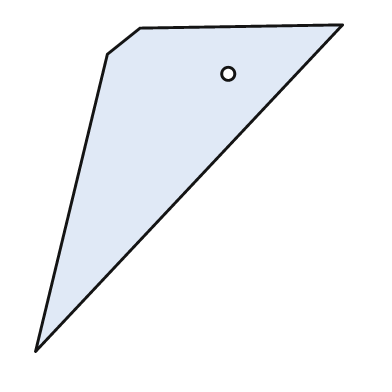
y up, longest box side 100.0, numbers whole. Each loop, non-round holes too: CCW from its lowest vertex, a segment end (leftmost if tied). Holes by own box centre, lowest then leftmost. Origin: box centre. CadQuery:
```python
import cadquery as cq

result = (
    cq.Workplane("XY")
    .moveTo(-47.0, -50.0)
    .lineTo(47.0, 50.0)
    .lineTo(-15.0, 49.0)
    .lineTo(-25.0, 41.0)
    .close()
    .moveTo(12.0, 35.0)
    .circle(2.0)
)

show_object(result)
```